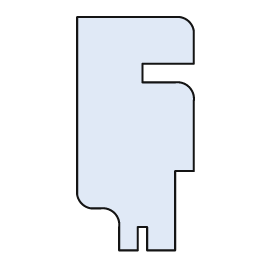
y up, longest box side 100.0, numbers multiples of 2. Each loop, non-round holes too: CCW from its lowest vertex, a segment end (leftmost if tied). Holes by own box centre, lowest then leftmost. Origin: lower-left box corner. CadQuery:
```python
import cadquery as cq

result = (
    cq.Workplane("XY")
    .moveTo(18.0, 0.0)
    .lineTo(26.0, 0.0)
    .lineTo(26.0, 10.0)
    .lineTo(30.0, 10.0)
    .lineTo(30.0, 0.0)
    .lineTo(42.0, 0.0)
    .lineTo(42.0, 34.0)
    .lineTo(50.0, 34.0)
    .lineTo(50.0, 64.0)
    .threePointArc((48.0, 70.0), (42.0, 72.0))
    .lineTo(28.0, 72.0)
    .lineTo(28.0, 80.0)
    .lineTo(50.0, 80.0)
    .lineTo(50.0, 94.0)
    .threePointArc((48.0, 98.0), (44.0, 100.0))
    .lineTo(0.0, 100.0)
    .lineTo(0.0, 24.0)
    .threePointArc((2.0, 20.0), (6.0, 18.0))
    .lineTo(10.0, 18.0)
    .threePointArc((16.0, 16.0), (18.0, 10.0))
    .close()
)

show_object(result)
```